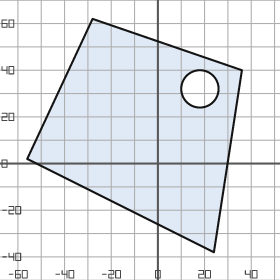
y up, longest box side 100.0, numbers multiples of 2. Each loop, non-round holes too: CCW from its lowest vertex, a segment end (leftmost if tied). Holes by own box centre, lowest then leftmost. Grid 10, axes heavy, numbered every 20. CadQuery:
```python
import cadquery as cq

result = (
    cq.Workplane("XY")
    .moveTo(24.0, -38.0)
    .lineTo(36.0, 40.0)
    .lineTo(-28.0, 62.0)
    .lineTo(-56.0, 2.0)
    .close()
    .moveTo(18.0, 32.0)
    .circle(8.0)
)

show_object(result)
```